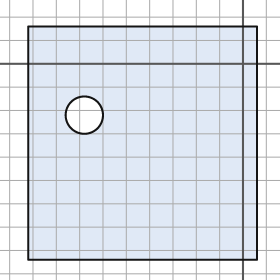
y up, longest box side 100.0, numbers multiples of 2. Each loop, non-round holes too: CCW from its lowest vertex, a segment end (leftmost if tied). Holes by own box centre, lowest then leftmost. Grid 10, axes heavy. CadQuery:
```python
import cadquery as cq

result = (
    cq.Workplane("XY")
    .moveTo(-92.0, -84.0)
    .lineTo(6.0, -84.0)
    .lineTo(6.0, 16.0)
    .lineTo(-92.0, 16.0)
    .close()
    .moveTo(-68.0, -22.0)
    .circle(8.0)
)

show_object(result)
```